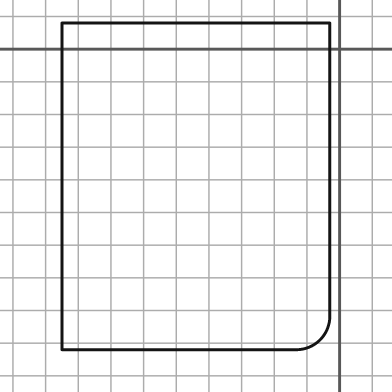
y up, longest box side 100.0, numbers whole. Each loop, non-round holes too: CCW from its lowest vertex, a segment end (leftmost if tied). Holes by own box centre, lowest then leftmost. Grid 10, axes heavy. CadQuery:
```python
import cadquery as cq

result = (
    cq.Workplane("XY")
    .moveTo(-85.0, -92.0)
    .lineTo(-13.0, -92.0)
    .threePointArc((-6.0, -89.0), (-3.0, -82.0))
    .lineTo(-3.0, 8.0)
    .lineTo(-85.0, 8.0)
    .close()
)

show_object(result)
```